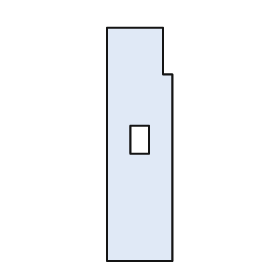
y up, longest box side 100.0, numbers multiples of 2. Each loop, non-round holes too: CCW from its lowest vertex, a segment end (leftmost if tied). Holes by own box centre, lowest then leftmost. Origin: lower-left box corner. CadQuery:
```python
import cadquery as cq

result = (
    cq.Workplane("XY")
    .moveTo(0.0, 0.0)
    .lineTo(28.0, 0.0)
    .lineTo(28.0, 80.0)
    .lineTo(24.0, 80.0)
    .lineTo(24.0, 100.0)
    .lineTo(0.0, 100.0)
    .close()
    .moveTo(10.0, 46.0)
    .lineTo(18.0, 46.0)
    .lineTo(18.0, 58.0)
    .lineTo(10.0, 58.0)
    .close()
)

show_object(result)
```